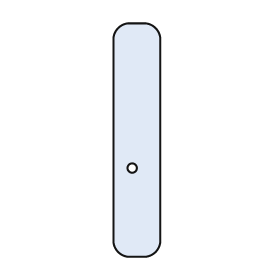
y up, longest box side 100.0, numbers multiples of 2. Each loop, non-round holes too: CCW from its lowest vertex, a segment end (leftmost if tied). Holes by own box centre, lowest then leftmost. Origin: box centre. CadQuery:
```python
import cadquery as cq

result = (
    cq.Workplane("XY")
    .moveTo(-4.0, -50.0)
    .lineTo(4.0, -50.0)
    .threePointArc((8.0, -48.0), (10.0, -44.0))
    .lineTo(10.0, 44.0)
    .threePointArc((8.0, 48.0), (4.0, 50.0))
    .lineTo(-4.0, 50.0)
    .threePointArc((-8.0, 48.0), (-10.0, 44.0))
    .lineTo(-10.0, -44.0)
    .threePointArc((-8.0, -48.0), (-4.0, -50.0))
    .close()
    .moveTo(-2.0, -12.0)
    .circle(2.0)
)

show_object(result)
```